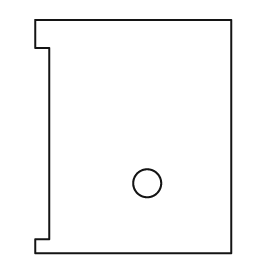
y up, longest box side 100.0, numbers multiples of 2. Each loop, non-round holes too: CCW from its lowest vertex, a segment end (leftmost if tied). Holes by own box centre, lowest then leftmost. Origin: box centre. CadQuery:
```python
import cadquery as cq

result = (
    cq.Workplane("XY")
    .moveTo(-42.0, -50.0)
    .lineTo(42.0, -50.0)
    .lineTo(42.0, 50.0)
    .lineTo(-42.0, 50.0)
    .lineTo(-42.0, 38.0)
    .lineTo(-36.0, 38.0)
    .lineTo(-36.0, -44.0)
    .lineTo(-42.0, -44.0)
    .close()
    .moveTo(6.0, -20.0)
    .circle(6.0)
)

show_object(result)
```